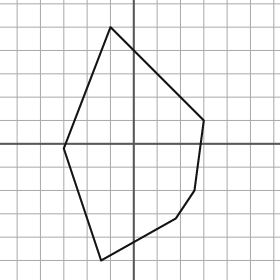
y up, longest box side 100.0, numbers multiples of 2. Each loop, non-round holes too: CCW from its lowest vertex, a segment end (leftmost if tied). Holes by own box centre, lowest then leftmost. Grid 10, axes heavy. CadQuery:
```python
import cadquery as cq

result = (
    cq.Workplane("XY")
    .moveTo(-14.0, -50.0)
    .lineTo(18.0, -32.0)
    .lineTo(26.0, -20.0)
    .lineTo(30.0, 10.0)
    .lineTo(-10.0, 50.0)
    .lineTo(-30.0, -2.0)
    .close()
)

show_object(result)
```